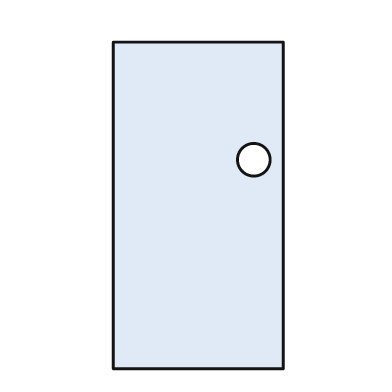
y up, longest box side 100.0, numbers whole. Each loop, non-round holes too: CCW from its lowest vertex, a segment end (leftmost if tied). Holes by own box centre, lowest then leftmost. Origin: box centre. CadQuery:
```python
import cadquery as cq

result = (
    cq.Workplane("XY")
    .moveTo(-26.0, -50.0)
    .lineTo(26.0, -50.0)
    .lineTo(26.0, 50.0)
    .lineTo(-26.0, 50.0)
    .close()
    .moveTo(17.0, 14.0)
    .circle(5.0)
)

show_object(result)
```